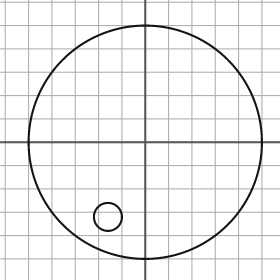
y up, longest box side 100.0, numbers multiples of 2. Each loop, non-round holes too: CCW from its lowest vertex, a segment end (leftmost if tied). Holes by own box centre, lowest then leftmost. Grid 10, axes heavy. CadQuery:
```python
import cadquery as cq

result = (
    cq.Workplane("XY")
    .moveTo(0.0, 0.0)
    .circle(50.0)
    .moveTo(-16.0, -32.0)
    .circle(6.0)
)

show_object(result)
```